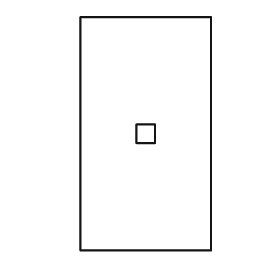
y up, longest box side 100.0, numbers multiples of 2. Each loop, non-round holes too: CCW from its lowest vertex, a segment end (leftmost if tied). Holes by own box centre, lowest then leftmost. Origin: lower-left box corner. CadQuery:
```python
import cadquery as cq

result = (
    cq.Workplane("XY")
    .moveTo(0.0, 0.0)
    .lineTo(56.0, 0.0)
    .lineTo(56.0, 100.0)
    .lineTo(0.0, 100.0)
    .close()
    .moveTo(24.0, 46.0)
    .lineTo(32.0, 46.0)
    .lineTo(32.0, 54.0)
    .lineTo(24.0, 54.0)
    .close()
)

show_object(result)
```